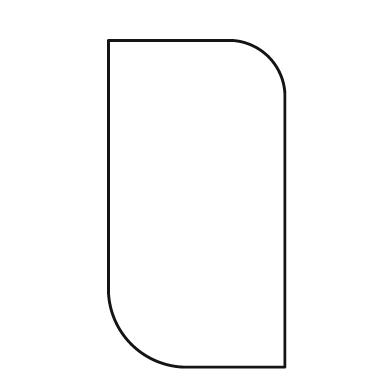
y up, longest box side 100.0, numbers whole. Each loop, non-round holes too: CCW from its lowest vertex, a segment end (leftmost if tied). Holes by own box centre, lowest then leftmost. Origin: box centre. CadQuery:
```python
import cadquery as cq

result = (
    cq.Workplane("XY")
    .moveTo(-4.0, -50.0)
    .lineTo(27.0, -50.0)
    .lineTo(27.0, 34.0)
    .threePointArc((22.0, 45.0), (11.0, 50.0))
    .lineTo(-27.0, 50.0)
    .lineTo(-27.0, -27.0)
    .threePointArc((-20.0, -43.0), (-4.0, -50.0))
    .close()
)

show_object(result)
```